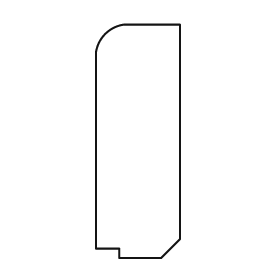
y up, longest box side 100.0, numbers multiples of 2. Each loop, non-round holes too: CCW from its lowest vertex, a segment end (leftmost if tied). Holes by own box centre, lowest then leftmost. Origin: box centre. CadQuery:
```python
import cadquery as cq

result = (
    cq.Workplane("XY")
    .moveTo(-8.0, -50.0)
    .lineTo(10.0, -50.0)
    .lineTo(18.0, -42.0)
    .lineTo(18.0, 50.0)
    .lineTo(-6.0, 50.0)
    .threePointArc((-14.0, 46.0), (-18.0, 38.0))
    .lineTo(-18.0, -46.0)
    .lineTo(-8.0, -46.0)
    .close()
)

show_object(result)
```